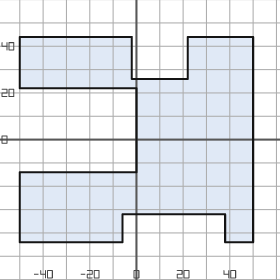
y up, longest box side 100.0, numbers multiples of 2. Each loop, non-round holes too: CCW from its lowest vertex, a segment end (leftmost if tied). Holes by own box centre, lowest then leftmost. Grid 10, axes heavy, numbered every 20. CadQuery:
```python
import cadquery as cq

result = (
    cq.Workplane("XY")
    .moveTo(-50.0, -44.0)
    .lineTo(-6.0, -44.0)
    .lineTo(-6.0, -32.0)
    .lineTo(38.0, -32.0)
    .lineTo(38.0, -44.0)
    .lineTo(50.0, -44.0)
    .lineTo(50.0, 44.0)
    .lineTo(22.0, 44.0)
    .lineTo(22.0, 26.0)
    .lineTo(-2.0, 26.0)
    .lineTo(-2.0, 44.0)
    .lineTo(-50.0, 44.0)
    .lineTo(-50.0, 22.0)
    .lineTo(0.0, 22.0)
    .lineTo(0.0, -14.0)
    .lineTo(-50.0, -14.0)
    .close()
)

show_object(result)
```